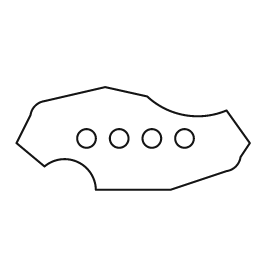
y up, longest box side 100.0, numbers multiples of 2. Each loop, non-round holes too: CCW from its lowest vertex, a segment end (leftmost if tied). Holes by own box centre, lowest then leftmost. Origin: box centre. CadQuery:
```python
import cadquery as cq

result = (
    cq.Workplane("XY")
    .moveTo(-16.0, -22.0)
    .lineTo(16.0, -22.0)
    .lineTo(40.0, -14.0)
    .threePointArc((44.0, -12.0), (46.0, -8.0))
    .lineTo(50.0, -2.0)
    .lineTo(40.0, 12.0)
    .threePointArc((22.0, 10.0), (6.0, 18.0))
    .lineTo(-12.0, 22.0)
    .lineTo(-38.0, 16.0)
    .threePointArc((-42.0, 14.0), (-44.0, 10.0))
    .lineTo(-50.0, -2.0)
    .lineTo(-38.0, -12.0)
    .threePointArc((-24.0, -10.0), (-16.0, -22.0))
    .close()
    .moveTo(-20.0, 0.0)
    .circle(4.0)
    .moveTo(-6.0, 0.0)
    .circle(4.0)
    .moveTo(8.0, 0.0)
    .circle(4.0)
    .moveTo(22.0, 0.0)
    .circle(4.0)
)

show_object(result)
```